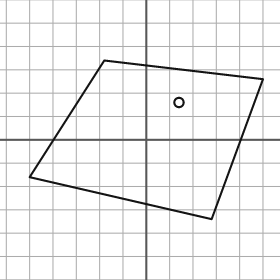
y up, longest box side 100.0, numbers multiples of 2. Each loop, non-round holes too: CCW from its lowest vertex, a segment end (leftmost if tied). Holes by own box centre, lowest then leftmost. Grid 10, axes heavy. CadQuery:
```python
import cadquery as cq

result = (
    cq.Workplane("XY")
    .moveTo(28.0, -34.0)
    .lineTo(50.0, 26.0)
    .lineTo(-18.0, 34.0)
    .lineTo(-50.0, -16.0)
    .close()
    .moveTo(14.0, 16.0)
    .circle(2.0)
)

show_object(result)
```